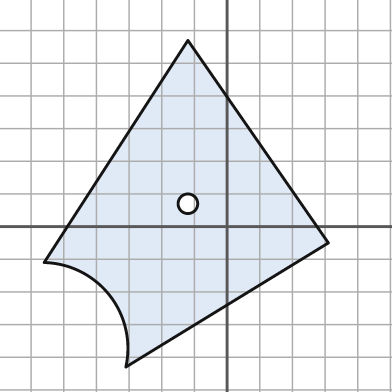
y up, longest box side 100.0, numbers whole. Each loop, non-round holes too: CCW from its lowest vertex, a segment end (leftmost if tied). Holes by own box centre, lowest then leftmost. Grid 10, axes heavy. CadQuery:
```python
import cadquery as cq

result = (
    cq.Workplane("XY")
    .moveTo(-31.0, -43.0)
    .lineTo(31.0, -5.0)
    .lineTo(-12.0, 57.0)
    .lineTo(-56.0, -11.0)
    .threePointArc((-36.0, -21.0), (-31.0, -43.0))
    .close()
    .moveTo(-12.0, 7.0)
    .circle(3.0)
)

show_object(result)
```